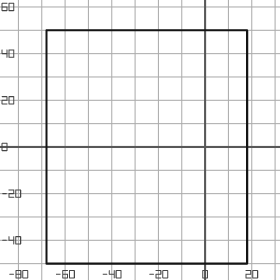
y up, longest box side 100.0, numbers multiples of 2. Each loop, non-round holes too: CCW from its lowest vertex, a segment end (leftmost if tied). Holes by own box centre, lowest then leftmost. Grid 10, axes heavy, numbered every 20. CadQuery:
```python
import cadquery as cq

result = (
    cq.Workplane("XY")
    .moveTo(-68.0, -50.0)
    .lineTo(18.0, -50.0)
    .lineTo(18.0, 50.0)
    .lineTo(-68.0, 50.0)
    .close()
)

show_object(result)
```